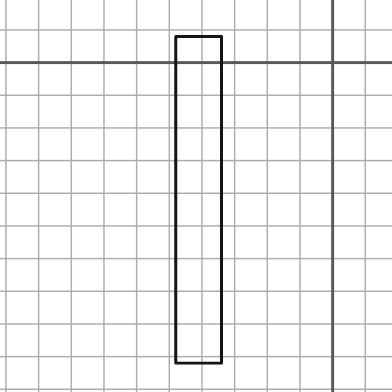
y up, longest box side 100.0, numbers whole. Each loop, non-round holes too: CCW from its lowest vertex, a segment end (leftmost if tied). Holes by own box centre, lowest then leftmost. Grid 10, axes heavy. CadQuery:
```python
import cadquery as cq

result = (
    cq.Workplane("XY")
    .moveTo(-48.0, -92.0)
    .lineTo(-34.0, -92.0)
    .lineTo(-34.0, 8.0)
    .lineTo(-48.0, 8.0)
    .close()
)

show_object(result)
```